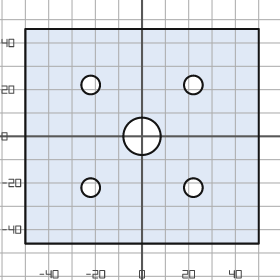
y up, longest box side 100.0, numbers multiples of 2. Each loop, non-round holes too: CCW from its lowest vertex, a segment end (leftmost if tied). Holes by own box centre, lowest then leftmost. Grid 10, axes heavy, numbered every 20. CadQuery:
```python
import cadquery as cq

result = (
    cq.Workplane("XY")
    .moveTo(-50.0, -46.0)
    .lineTo(50.0, -46.0)
    .lineTo(50.0, 46.0)
    .lineTo(-50.0, 46.0)
    .close()
    .moveTo(-22.0, -22.0)
    .circle(4.0)
    .moveTo(22.0, -22.0)
    .circle(4.0)
    .moveTo(0.0, 0.0)
    .circle(8.0)
    .moveTo(-22.0, 22.0)
    .circle(4.0)
    .moveTo(22.0, 22.0)
    .circle(4.0)
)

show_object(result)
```